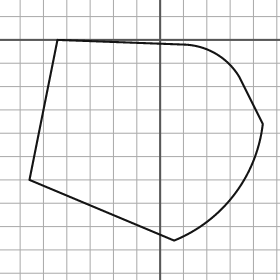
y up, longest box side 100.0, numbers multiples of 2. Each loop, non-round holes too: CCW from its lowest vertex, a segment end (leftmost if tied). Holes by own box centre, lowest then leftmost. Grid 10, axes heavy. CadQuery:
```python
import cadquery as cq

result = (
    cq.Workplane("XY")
    .moveTo(6.0, -86.0)
    .threePointArc((32.0, -66.0), (44.0, -36.0))
    .lineTo(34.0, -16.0)
    .threePointArc((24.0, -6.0), (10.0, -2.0))
    .lineTo(-44.0, 0.0)
    .lineTo(-56.0, -60.0)
    .close()
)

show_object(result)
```